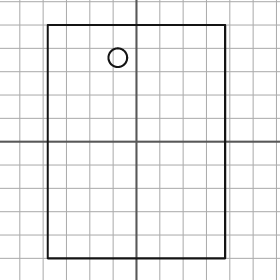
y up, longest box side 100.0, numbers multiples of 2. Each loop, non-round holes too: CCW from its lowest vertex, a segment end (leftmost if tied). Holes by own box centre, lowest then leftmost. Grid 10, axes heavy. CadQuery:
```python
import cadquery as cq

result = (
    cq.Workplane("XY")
    .moveTo(-38.0, -50.0)
    .lineTo(38.0, -50.0)
    .lineTo(38.0, 50.0)
    .lineTo(-38.0, 50.0)
    .close()
    .moveTo(-8.0, 36.0)
    .circle(4.0)
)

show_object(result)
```